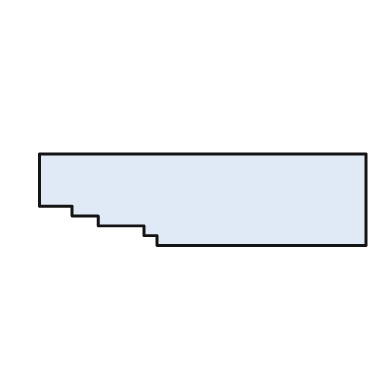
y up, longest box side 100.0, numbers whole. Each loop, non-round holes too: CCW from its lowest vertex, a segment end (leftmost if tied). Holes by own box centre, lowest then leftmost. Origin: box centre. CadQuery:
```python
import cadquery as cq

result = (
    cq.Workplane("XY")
    .moveTo(-14.0, -14.0)
    .lineTo(50.0, -14.0)
    .lineTo(50.0, 14.0)
    .lineTo(-50.0, 14.0)
    .lineTo(-50.0, -2.0)
    .lineTo(-40.0, -2.0)
    .lineTo(-40.0, -5.0)
    .lineTo(-32.0, -5.0)
    .lineTo(-32.0, -8.0)
    .lineTo(-18.0, -8.0)
    .lineTo(-18.0, -11.0)
    .lineTo(-14.0, -11.0)
    .close()
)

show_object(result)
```